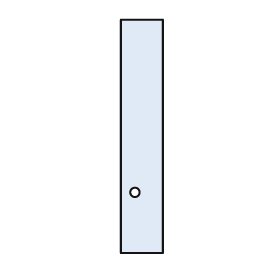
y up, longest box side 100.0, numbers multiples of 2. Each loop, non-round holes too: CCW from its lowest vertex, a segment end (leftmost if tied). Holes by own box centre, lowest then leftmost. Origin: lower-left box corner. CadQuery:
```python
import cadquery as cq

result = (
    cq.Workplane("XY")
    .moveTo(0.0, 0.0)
    .lineTo(18.0, 0.0)
    .lineTo(18.0, 100.0)
    .lineTo(0.0, 100.0)
    .close()
    .moveTo(6.0, 26.0)
    .circle(2.0)
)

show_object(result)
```